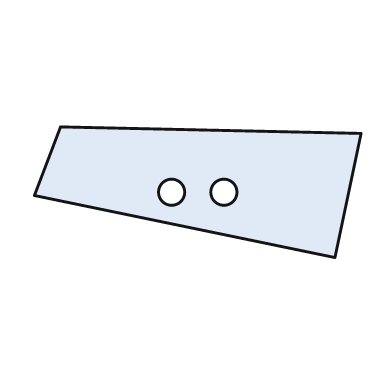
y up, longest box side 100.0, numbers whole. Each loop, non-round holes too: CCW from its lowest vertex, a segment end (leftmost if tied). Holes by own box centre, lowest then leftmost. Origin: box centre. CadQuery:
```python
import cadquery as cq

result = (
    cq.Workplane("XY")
    .moveTo(42.0, -20.0)
    .lineTo(50.0, 18.0)
    .lineTo(-42.0, 20.0)
    .lineTo(-50.0, -1.0)
    .close()
    .moveTo(-8.0, 0.0)
    .circle(4.0)
    .moveTo(8.0, 0.0)
    .circle(4.0)
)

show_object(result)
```